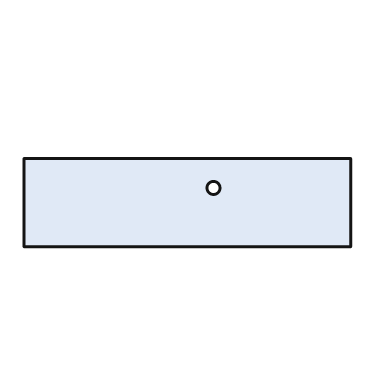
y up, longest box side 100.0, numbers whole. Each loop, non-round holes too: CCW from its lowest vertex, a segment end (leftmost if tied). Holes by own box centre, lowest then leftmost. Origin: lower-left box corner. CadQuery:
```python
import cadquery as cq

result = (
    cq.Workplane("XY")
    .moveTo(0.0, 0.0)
    .lineTo(100.0, 0.0)
    .lineTo(100.0, 27.0)
    .lineTo(0.0, 27.0)
    .close()
    .moveTo(58.0, 18.0)
    .circle(2.0)
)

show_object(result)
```